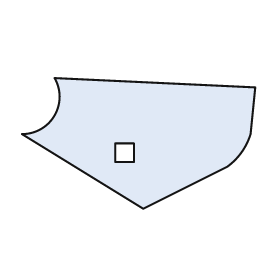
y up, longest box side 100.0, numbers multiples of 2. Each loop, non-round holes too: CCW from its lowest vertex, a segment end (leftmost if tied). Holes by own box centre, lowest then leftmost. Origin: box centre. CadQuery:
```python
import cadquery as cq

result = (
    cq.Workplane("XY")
    .moveTo(2.0, -28.0)
    .lineTo(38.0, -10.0)
    .threePointArc((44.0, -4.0), (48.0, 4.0))
    .lineTo(50.0, 24.0)
    .lineTo(-36.0, 28.0)
    .threePointArc((-36.0, 12.0), (-50.0, 4.0))
    .close()
    .moveTo(-10.0, -8.0)
    .lineTo(-2.0, -8.0)
    .lineTo(-2.0, 0.0)
    .lineTo(-10.0, 0.0)
    .close()
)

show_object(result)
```